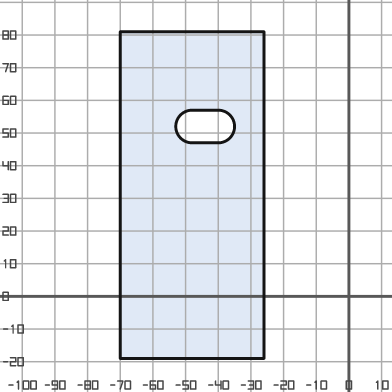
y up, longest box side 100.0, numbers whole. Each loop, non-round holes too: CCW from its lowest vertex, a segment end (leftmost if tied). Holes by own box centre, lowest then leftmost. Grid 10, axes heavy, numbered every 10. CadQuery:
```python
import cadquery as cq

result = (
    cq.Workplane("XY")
    .moveTo(-70.0, -19.0)
    .lineTo(-26.0, -19.0)
    .lineTo(-26.0, 81.0)
    .lineTo(-70.0, 81.0)
    .close()
    .moveTo(-48.0, 47.0)
    .lineTo(-40.0, 47.0)
    .threePointArc((-35.0, 52.0), (-40.0, 57.0))
    .lineTo(-48.0, 57.0)
    .threePointArc((-53.0, 52.0), (-48.0, 47.0))
    .close()
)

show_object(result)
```